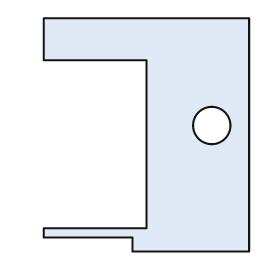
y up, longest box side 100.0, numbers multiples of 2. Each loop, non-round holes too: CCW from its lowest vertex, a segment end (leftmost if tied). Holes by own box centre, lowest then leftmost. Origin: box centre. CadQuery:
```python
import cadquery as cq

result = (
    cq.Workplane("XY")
    .moveTo(-6.0, -50.0)
    .lineTo(44.0, -50.0)
    .lineTo(44.0, 50.0)
    .lineTo(-44.0, 50.0)
    .lineTo(-44.0, 32.0)
    .lineTo(0.0, 32.0)
    .lineTo(0.0, -40.0)
    .lineTo(-44.0, -40.0)
    .lineTo(-44.0, -44.0)
    .lineTo(-6.0, -44.0)
    .close()
    .moveTo(28.0, 4.0)
    .circle(8.0)
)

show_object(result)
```